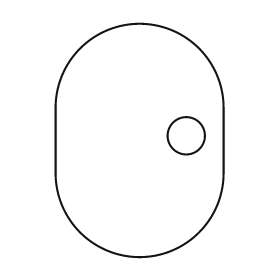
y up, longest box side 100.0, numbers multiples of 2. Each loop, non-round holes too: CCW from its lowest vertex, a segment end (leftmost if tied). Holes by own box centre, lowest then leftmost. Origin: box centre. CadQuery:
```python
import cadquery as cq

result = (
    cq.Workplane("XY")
    .moveTo(-36.0, -14.0)
    .threePointArc((0.0, -50.0), (36.0, -14.0))
    .lineTo(36.0, 14.0)
    .threePointArc((0.0, 50.0), (-36.0, 14.0))
    .close()
    .moveTo(20.0, 2.0)
    .circle(8.0)
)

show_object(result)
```